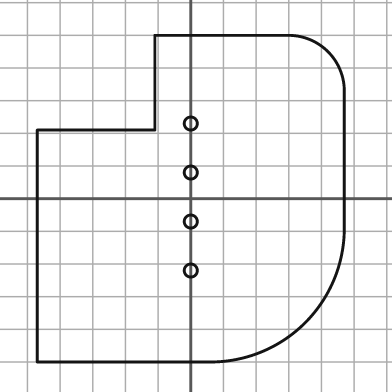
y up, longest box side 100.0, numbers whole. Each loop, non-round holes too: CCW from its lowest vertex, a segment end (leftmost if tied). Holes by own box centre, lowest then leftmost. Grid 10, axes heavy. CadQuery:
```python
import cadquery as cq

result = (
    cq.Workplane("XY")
    .moveTo(-47.0, -50.0)
    .lineTo(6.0, -50.0)
    .threePointArc((35.0, -38.0), (47.0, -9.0))
    .lineTo(47.0, 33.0)
    .threePointArc((42.0, 45.0), (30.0, 50.0))
    .lineTo(-11.0, 50.0)
    .lineTo(-11.0, 21.0)
    .lineTo(-47.0, 21.0)
    .close()
    .moveTo(0.0, -22.0)
    .circle(2.0)
    .moveTo(0.0, -7.0)
    .circle(2.0)
    .moveTo(0.0, 8.0)
    .circle(2.0)
    .moveTo(0.0, 23.0)
    .circle(2.0)
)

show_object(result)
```